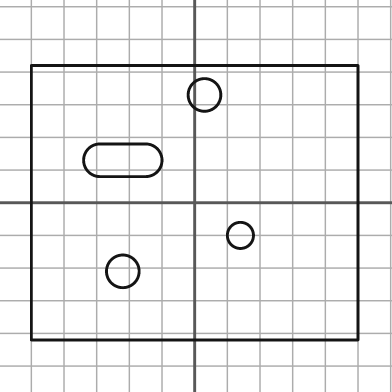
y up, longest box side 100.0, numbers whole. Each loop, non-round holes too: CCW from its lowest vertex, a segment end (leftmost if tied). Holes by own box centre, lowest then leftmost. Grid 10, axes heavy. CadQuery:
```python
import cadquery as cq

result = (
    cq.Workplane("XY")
    .moveTo(-50.0, -42.0)
    .lineTo(50.0, -42.0)
    .lineTo(50.0, 42.0)
    .lineTo(-50.0, 42.0)
    .close()
    .moveTo(-22.0, -21.0)
    .circle(5.0)
    .moveTo(14.0, -10.0)
    .circle(4.0)
    .moveTo(-29.0, 8.0)
    .lineTo(-15.0, 8.0)
    .threePointArc((-10.0, 13.0), (-15.0, 18.0))
    .lineTo(-29.0, 18.0)
    .threePointArc((-34.0, 13.0), (-29.0, 8.0))
    .close()
    .moveTo(3.0, 33.0)
    .circle(5.0)
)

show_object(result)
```